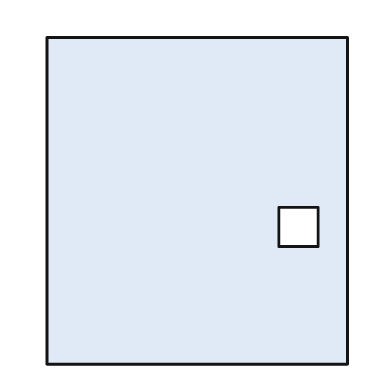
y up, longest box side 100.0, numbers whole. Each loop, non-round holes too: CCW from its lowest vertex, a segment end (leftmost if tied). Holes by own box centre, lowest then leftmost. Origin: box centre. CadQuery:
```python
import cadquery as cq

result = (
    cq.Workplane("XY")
    .moveTo(-46.0, -50.0)
    .lineTo(46.0, -50.0)
    .lineTo(46.0, 50.0)
    .lineTo(-46.0, 50.0)
    .close()
    .moveTo(25.0, -14.0)
    .lineTo(37.0, -14.0)
    .lineTo(37.0, -2.0)
    .lineTo(25.0, -2.0)
    .close()
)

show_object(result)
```